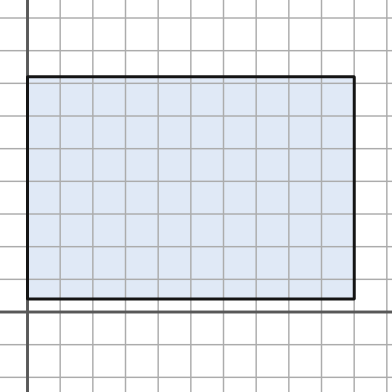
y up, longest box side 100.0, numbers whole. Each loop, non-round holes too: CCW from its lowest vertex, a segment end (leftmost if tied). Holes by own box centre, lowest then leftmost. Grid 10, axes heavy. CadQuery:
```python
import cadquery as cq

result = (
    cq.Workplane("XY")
    .moveTo(0.0, 4.0)
    .lineTo(100.0, 4.0)
    .lineTo(100.0, 72.0)
    .lineTo(0.0, 72.0)
    .close()
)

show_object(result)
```